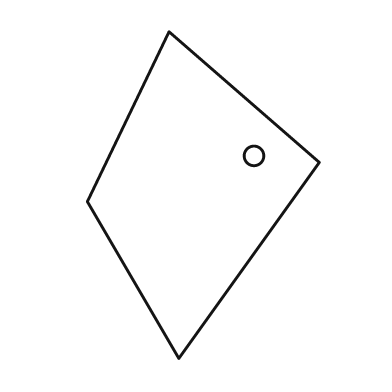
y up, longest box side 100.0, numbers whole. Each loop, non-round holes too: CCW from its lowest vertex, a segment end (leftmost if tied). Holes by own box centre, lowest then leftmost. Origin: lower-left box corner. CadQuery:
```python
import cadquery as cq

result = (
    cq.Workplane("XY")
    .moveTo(28.0, 0.0)
    .lineTo(71.0, 60.0)
    .lineTo(25.0, 100.0)
    .lineTo(0.0, 48.0)
    .close()
    .moveTo(51.0, 62.0)
    .circle(3.0)
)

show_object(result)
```